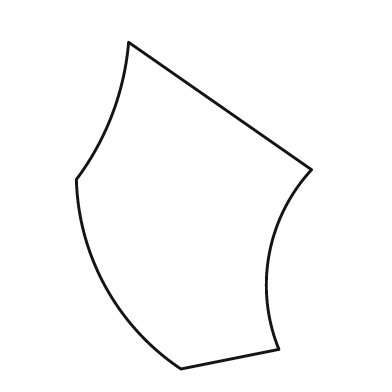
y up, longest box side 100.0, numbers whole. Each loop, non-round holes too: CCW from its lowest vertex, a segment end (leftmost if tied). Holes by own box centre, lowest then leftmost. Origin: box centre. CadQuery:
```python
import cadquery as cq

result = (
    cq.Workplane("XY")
    .moveTo(-4.0, -50.0)
    .lineTo(26.0, -44.0)
    .threePointArc((23.0, -15.0), (36.0, 11.0))
    .lineTo(-20.0, 50.0)
    .threePointArc((-25.0, 28.0), (-36.0, 8.0))
    .threePointArc((-27.0, -25.0), (-4.0, -50.0))
    .close()
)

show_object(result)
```